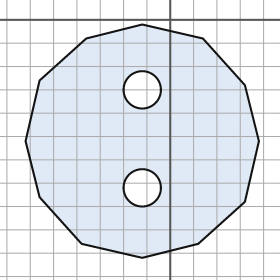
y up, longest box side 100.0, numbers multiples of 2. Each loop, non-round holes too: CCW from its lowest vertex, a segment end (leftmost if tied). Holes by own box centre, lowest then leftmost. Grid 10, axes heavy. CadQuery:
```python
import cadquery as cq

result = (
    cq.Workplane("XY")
    .moveTo(-12.0, -102.0)
    .lineTo(12.0, -96.0)
    .lineTo(32.0, -78.0)
    .lineTo(38.0, -52.0)
    .lineTo(32.0, -28.0)
    .lineTo(14.0, -8.0)
    .lineTo(-12.0, -2.0)
    .lineTo(-36.0, -8.0)
    .lineTo(-56.0, -26.0)
    .lineTo(-62.0, -52.0)
    .lineTo(-56.0, -76.0)
    .lineTo(-38.0, -96.0)
    .close()
    .moveTo(-12.0, -72.0)
    .circle(8.0)
    .moveTo(-12.0, -30.0)
    .circle(8.0)
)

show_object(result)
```